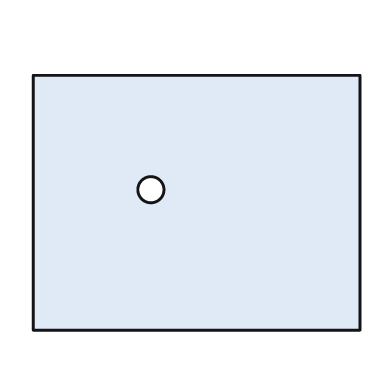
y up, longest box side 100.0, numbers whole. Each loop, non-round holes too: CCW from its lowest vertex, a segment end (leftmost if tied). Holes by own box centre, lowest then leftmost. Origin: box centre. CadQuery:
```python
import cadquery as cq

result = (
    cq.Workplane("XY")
    .moveTo(-50.0, -39.0)
    .lineTo(50.0, -39.0)
    .lineTo(50.0, 39.0)
    .lineTo(-50.0, 39.0)
    .close()
    .moveTo(-14.0, 4.0)
    .circle(4.0)
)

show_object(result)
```